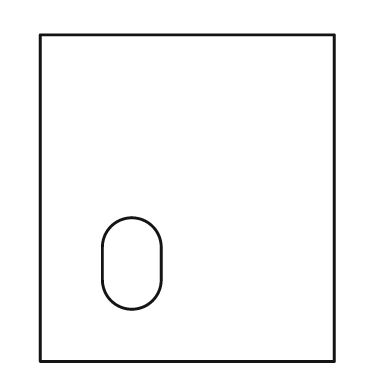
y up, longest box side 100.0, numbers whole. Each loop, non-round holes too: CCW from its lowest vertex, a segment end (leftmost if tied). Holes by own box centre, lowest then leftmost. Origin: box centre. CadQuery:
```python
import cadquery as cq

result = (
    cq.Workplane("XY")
    .moveTo(-45.0, -50.0)
    .lineTo(45.0, -50.0)
    .lineTo(45.0, 50.0)
    .lineTo(-45.0, 50.0)
    .close()
    .moveTo(-26.0, -25.0)
    .threePointArc((-17.0, -34.0), (-8.0, -25.0))
    .lineTo(-8.0, -15.0)
    .threePointArc((-17.0, -6.0), (-26.0, -15.0))
    .close()
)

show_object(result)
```